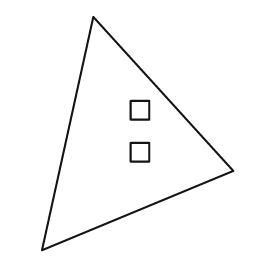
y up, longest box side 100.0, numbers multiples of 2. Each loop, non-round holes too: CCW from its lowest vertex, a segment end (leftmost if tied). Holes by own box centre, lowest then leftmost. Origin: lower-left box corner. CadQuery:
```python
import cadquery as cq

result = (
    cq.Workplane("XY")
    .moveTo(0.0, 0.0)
    .lineTo(82.0, 34.0)
    .lineTo(22.0, 100.0)
    .close()
    .moveTo(38.0, 38.0)
    .lineTo(46.0, 38.0)
    .lineTo(46.0, 46.0)
    .lineTo(38.0, 46.0)
    .close()
    .moveTo(38.0, 56.0)
    .lineTo(46.0, 56.0)
    .lineTo(46.0, 64.0)
    .lineTo(38.0, 64.0)
    .close()
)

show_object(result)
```